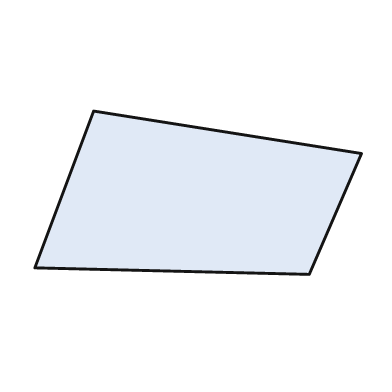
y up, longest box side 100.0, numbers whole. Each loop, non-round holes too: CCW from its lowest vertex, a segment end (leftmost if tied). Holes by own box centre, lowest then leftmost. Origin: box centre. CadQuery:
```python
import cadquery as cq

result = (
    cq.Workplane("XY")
    .moveTo(34.0, -25.0)
    .lineTo(50.0, 12.0)
    .lineTo(-32.0, 25.0)
    .lineTo(-50.0, -23.0)
    .close()
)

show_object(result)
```